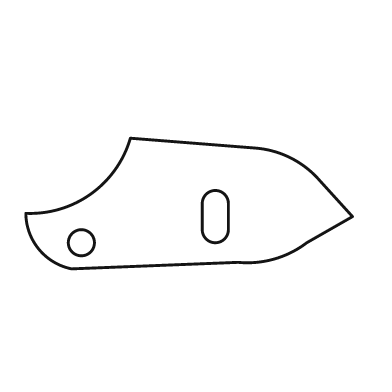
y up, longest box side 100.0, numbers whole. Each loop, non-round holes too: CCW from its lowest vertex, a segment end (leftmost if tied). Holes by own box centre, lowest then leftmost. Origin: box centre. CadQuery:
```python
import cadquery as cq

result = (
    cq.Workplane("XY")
    .moveTo(-36.0, -20.0)
    .lineTo(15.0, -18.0)
    .threePointArc((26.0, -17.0), (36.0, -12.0))
    .lineTo(50.0, -4.0)
    .lineTo(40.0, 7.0)
    .threePointArc((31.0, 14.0), (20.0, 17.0))
    .lineTo(-18.0, 20.0)
    .threePointArc((-30.0, 3.0), (-50.0, -3.0))
    .threePointArc((-46.0, -14.0), (-36.0, -20.0))
    .close()
    .moveTo(-33.0, -12.0)
    .circle(4.0)
    .moveTo(4.0, -8.0)
    .threePointArc((8.0, -12.0), (12.0, -8.0))
    .lineTo(12.0, 0.0)
    .threePointArc((8.0, 4.0), (4.0, 0.0))
    .close()
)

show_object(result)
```